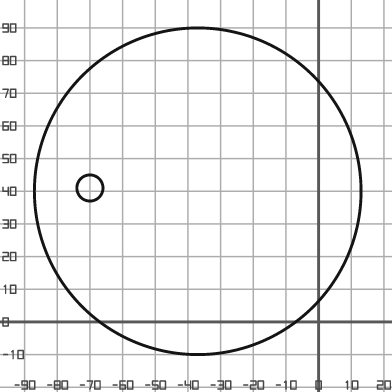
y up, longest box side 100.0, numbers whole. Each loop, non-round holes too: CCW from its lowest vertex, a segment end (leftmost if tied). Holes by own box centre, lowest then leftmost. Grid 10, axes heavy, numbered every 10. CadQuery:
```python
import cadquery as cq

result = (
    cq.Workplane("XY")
    .moveTo(-37.0, 40.0)
    .circle(50.0)
    .moveTo(-70.0, 41.0)
    .circle(4.0)
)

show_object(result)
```